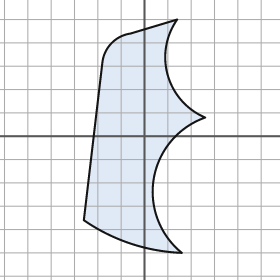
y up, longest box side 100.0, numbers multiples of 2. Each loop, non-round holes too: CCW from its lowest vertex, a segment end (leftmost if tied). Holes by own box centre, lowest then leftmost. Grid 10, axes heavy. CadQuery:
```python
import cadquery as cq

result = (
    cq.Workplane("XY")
    .moveTo(16.0, -50.0)
    .threePointArc((4.0, -18.0), (26.0, 8.0))
    .threePointArc((10.0, 26.0), (14.0, 50.0))
    .lineTo(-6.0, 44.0)
    .threePointArc((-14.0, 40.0), (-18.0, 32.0))
    .lineTo(-26.0, -36.0)
    .threePointArc((-6.0, -46.0), (16.0, -50.0))
    .close()
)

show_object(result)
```